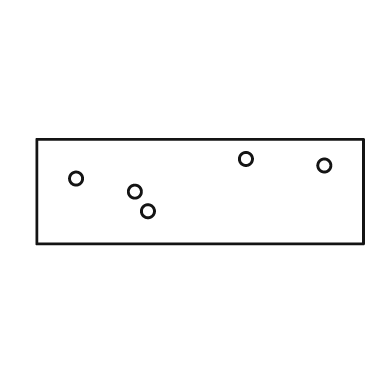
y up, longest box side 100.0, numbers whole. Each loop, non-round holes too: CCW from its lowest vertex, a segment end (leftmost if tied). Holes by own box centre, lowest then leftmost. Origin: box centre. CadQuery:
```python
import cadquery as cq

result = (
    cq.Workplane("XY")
    .moveTo(-50.0, -16.0)
    .lineTo(50.0, -16.0)
    .lineTo(50.0, 16.0)
    .lineTo(-50.0, 16.0)
    .close()
    .moveTo(-16.0, -6.0)
    .circle(2.0)
    .moveTo(-20.0, 0.0)
    .circle(2.0)
    .moveTo(-38.0, 4.0)
    .circle(2.0)
    .moveTo(38.0, 8.0)
    .circle(2.0)
    .moveTo(14.0, 10.0)
    .circle(2.0)
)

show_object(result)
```